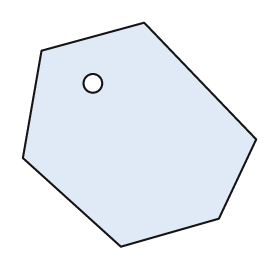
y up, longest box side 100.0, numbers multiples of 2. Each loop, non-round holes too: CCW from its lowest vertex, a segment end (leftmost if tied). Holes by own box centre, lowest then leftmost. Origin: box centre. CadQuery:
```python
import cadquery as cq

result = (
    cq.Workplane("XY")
    .moveTo(-8.0, -48.0)
    .lineTo(34.0, -36.0)
    .lineTo(50.0, -2.0)
    .lineTo(2.0, 48.0)
    .lineTo(-42.0, 36.0)
    .lineTo(-50.0, -10.0)
    .close()
    .moveTo(-20.0, 22.0)
    .circle(4.0)
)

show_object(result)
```